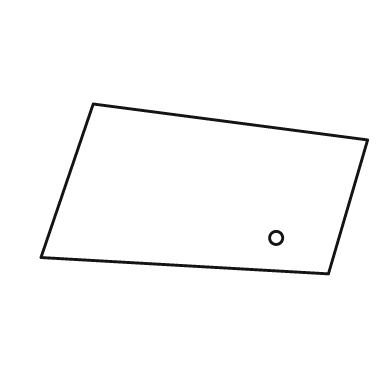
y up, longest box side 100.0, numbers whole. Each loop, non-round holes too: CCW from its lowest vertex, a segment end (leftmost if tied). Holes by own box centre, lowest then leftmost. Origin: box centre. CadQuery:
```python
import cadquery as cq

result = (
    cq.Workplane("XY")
    .moveTo(38.0, -26.0)
    .lineTo(50.0, 15.0)
    .lineTo(-34.0, 26.0)
    .lineTo(-50.0, -21.0)
    .close()
    .moveTo(22.0, -15.0)
    .circle(2.0)
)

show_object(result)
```